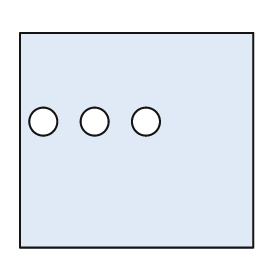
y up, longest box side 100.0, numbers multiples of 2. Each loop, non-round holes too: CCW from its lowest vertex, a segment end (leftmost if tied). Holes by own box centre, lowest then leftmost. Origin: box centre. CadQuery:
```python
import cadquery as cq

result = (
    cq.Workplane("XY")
    .moveTo(-50.0, -46.0)
    .lineTo(50.0, -46.0)
    .lineTo(50.0, 46.0)
    .lineTo(-50.0, 46.0)
    .close()
    .moveTo(-40.0, 8.0)
    .circle(6.0)
    .moveTo(-18.0, 8.0)
    .circle(6.0)
    .moveTo(4.0, 8.0)
    .circle(6.0)
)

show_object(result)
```